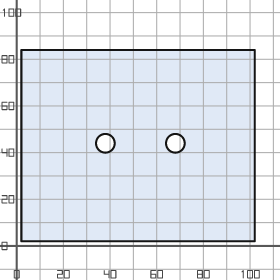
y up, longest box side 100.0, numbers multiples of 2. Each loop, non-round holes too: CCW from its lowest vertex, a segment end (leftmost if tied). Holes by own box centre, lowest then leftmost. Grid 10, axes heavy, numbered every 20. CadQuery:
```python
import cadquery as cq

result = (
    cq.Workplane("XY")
    .moveTo(2.0, 2.0)
    .lineTo(102.0, 2.0)
    .lineTo(102.0, 84.0)
    .lineTo(2.0, 84.0)
    .close()
    .moveTo(38.0, 44.0)
    .circle(4.0)
    .moveTo(68.0, 44.0)
    .circle(4.0)
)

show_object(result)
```